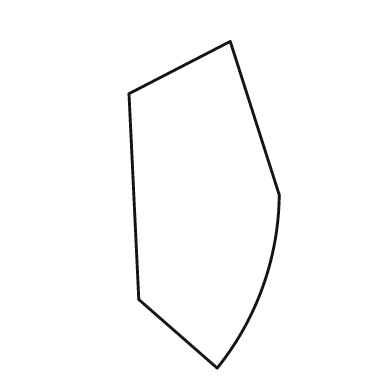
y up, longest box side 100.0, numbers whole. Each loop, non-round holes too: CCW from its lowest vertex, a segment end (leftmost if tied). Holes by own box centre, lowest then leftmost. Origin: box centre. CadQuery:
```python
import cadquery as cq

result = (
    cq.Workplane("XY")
    .moveTo(4.0, -50.0)
    .threePointArc((18.0, -25.0), (23.0, 3.0))
    .lineTo(8.0, 50.0)
    .lineTo(-23.0, 34.0)
    .lineTo(-20.0, -29.0)
    .close()
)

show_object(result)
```